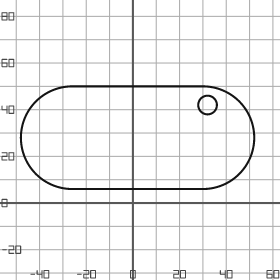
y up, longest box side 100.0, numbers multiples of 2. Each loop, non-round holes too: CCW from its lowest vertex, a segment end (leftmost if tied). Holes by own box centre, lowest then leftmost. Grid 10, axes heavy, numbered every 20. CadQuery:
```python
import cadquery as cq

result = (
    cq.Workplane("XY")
    .moveTo(-26.0, 6.0)
    .lineTo(30.0, 6.0)
    .threePointArc((52.0, 28.0), (30.0, 50.0))
    .lineTo(-26.0, 50.0)
    .threePointArc((-48.0, 28.0), (-26.0, 6.0))
    .close()
    .moveTo(32.0, 42.0)
    .circle(4.0)
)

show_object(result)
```